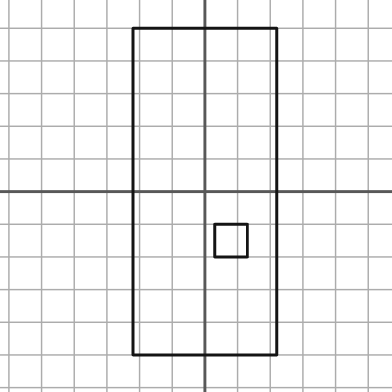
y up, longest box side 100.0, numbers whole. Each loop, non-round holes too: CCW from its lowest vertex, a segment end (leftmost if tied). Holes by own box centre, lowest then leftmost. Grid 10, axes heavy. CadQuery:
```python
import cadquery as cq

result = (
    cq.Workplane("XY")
    .moveTo(-22.0, -50.0)
    .lineTo(22.0, -50.0)
    .lineTo(22.0, 50.0)
    .lineTo(-22.0, 50.0)
    .close()
    .moveTo(3.0, -20.0)
    .lineTo(13.0, -20.0)
    .lineTo(13.0, -10.0)
    .lineTo(3.0, -10.0)
    .close()
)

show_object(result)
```